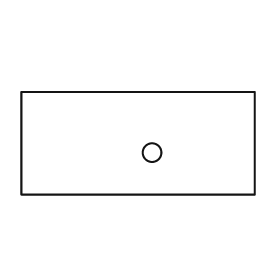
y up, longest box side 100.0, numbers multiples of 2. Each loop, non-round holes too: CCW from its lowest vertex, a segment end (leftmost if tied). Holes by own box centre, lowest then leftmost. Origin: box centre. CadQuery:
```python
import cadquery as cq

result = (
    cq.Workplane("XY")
    .moveTo(-50.0, -22.0)
    .lineTo(50.0, -22.0)
    .lineTo(50.0, 22.0)
    .lineTo(-50.0, 22.0)
    .close()
    .moveTo(6.0, -4.0)
    .circle(4.0)
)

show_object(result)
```